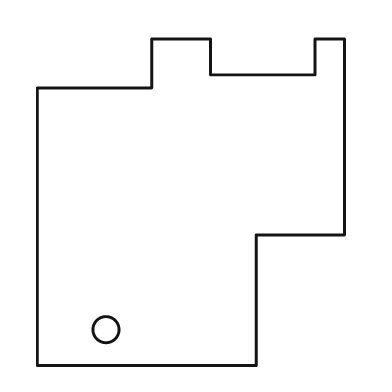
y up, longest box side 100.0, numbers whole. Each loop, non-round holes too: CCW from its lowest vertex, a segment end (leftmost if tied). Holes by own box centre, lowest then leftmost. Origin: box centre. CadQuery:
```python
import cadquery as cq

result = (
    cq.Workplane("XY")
    .moveTo(-47.0, -50.0)
    .lineTo(20.0, -50.0)
    .lineTo(20.0, -10.0)
    .lineTo(47.0, -10.0)
    .lineTo(47.0, 50.0)
    .lineTo(38.0, 50.0)
    .lineTo(38.0, 39.0)
    .lineTo(6.0, 39.0)
    .lineTo(6.0, 50.0)
    .lineTo(-12.0, 50.0)
    .lineTo(-12.0, 35.0)
    .lineTo(-47.0, 35.0)
    .close()
    .moveTo(-26.0, -39.0)
    .circle(4.0)
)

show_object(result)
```